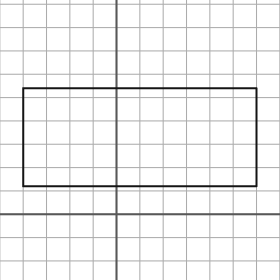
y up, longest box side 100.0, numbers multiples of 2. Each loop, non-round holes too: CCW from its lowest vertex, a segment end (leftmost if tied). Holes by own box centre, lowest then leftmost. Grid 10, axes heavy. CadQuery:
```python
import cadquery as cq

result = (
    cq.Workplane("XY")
    .moveTo(-40.0, 12.0)
    .lineTo(60.0, 12.0)
    .lineTo(60.0, 54.0)
    .lineTo(-40.0, 54.0)
    .close()
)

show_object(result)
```